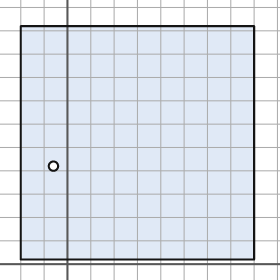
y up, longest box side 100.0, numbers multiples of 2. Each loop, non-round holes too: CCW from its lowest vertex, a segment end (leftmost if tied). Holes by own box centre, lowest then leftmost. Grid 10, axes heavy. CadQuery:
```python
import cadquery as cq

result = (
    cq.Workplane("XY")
    .moveTo(-20.0, 2.0)
    .lineTo(80.0, 2.0)
    .lineTo(80.0, 102.0)
    .lineTo(-20.0, 102.0)
    .close()
    .moveTo(-6.0, 42.0)
    .circle(2.0)
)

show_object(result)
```